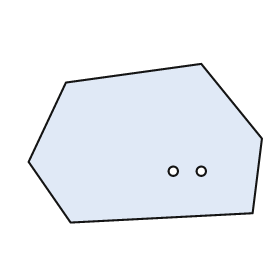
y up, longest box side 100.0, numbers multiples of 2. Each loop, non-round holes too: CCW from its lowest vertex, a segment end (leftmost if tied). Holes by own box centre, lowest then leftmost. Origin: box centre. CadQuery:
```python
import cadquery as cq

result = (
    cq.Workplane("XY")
    .moveTo(-32.0, -34.0)
    .lineTo(46.0, -30.0)
    .lineTo(50.0, 2.0)
    .lineTo(24.0, 34.0)
    .lineTo(-34.0, 26.0)
    .lineTo(-50.0, -8.0)
    .close()
    .moveTo(12.0, -12.0)
    .circle(2.0)
    .moveTo(24.0, -12.0)
    .circle(2.0)
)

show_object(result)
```